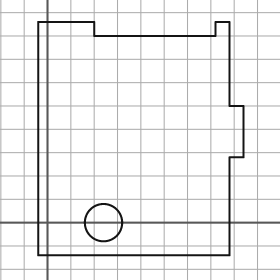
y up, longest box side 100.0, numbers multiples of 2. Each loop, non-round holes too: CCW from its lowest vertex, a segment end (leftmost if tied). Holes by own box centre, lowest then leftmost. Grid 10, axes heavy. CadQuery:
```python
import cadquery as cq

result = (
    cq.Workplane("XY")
    .moveTo(-4.0, -14.0)
    .lineTo(78.0, -14.0)
    .lineTo(78.0, 28.0)
    .lineTo(84.0, 28.0)
    .lineTo(84.0, 50.0)
    .lineTo(78.0, 50.0)
    .lineTo(78.0, 86.0)
    .lineTo(72.0, 86.0)
    .lineTo(72.0, 80.0)
    .lineTo(20.0, 80.0)
    .lineTo(20.0, 86.0)
    .lineTo(-4.0, 86.0)
    .close()
    .moveTo(24.0, 0.0)
    .circle(8.0)
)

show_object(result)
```